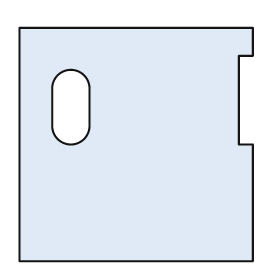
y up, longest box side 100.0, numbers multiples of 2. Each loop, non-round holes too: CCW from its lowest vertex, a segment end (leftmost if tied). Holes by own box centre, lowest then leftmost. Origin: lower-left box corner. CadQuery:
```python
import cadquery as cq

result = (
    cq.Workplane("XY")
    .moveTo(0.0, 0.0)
    .lineTo(100.0, 0.0)
    .lineTo(100.0, 50.0)
    .lineTo(94.0, 50.0)
    .lineTo(94.0, 88.0)
    .lineTo(100.0, 88.0)
    .lineTo(100.0, 100.0)
    .lineTo(0.0, 100.0)
    .close()
    .moveTo(14.0, 58.0)
    .threePointArc((22.0, 50.0), (30.0, 58.0))
    .lineTo(30.0, 74.0)
    .threePointArc((22.0, 82.0), (14.0, 74.0))
    .close()
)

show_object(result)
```